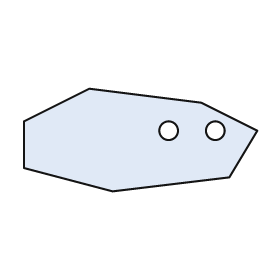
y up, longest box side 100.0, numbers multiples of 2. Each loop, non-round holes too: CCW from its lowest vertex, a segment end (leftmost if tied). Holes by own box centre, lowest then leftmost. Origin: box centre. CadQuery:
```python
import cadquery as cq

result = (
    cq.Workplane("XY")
    .moveTo(-12.0, -22.0)
    .lineTo(38.0, -16.0)
    .lineTo(50.0, 4.0)
    .lineTo(26.0, 16.0)
    .lineTo(-22.0, 22.0)
    .lineTo(-50.0, 8.0)
    .lineTo(-50.0, -12.0)
    .close()
    .moveTo(12.0, 4.0)
    .circle(4.0)
    .moveTo(32.0, 4.0)
    .circle(4.0)
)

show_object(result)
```